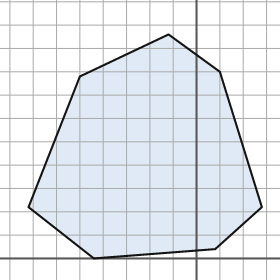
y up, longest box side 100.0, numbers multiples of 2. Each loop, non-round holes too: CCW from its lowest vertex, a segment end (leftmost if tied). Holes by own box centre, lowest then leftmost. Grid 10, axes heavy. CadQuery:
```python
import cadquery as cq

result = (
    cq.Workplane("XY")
    .moveTo(-44.0, 0.0)
    .lineTo(8.0, 4.0)
    .lineTo(28.0, 22.0)
    .lineTo(10.0, 80.0)
    .lineTo(-12.0, 96.0)
    .lineTo(-50.0, 78.0)
    .lineTo(-72.0, 22.0)
    .close()
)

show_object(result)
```